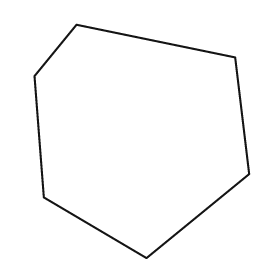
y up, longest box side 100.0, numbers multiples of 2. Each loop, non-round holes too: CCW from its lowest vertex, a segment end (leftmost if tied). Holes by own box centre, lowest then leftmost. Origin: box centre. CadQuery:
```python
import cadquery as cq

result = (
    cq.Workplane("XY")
    .moveTo(2.0, -50.0)
    .lineTo(46.0, -14.0)
    .lineTo(40.0, 36.0)
    .lineTo(-28.0, 50.0)
    .lineTo(-46.0, 28.0)
    .lineTo(-42.0, -24.0)
    .close()
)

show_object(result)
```